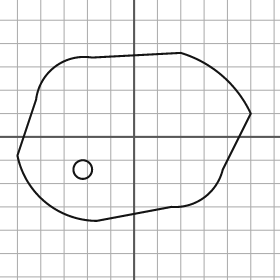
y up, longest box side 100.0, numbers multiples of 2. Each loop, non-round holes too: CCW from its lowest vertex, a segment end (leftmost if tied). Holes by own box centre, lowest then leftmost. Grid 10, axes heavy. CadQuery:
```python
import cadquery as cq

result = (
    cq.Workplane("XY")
    .moveTo(-16.0, -36.0)
    .lineTo(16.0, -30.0)
    .threePointArc((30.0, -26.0), (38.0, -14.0))
    .lineTo(50.0, 10.0)
    .threePointArc((38.0, 26.0), (20.0, 36.0))
    .lineTo(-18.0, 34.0)
    .threePointArc((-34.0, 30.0), (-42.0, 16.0))
    .lineTo(-50.0, -8.0)
    .threePointArc((-38.0, -28.0), (-16.0, -36.0))
    .close()
    .moveTo(-22.0, -14.0)
    .circle(4.0)
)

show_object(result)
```